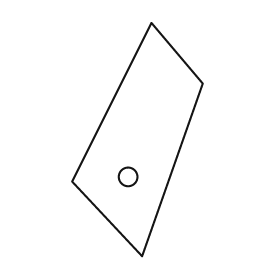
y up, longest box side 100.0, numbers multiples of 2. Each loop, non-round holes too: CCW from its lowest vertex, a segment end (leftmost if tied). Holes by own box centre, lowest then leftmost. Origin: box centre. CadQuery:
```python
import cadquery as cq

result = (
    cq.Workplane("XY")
    .moveTo(2.0, -50.0)
    .lineTo(28.0, 24.0)
    .lineTo(6.0, 50.0)
    .lineTo(-28.0, -18.0)
    .close()
    .moveTo(-4.0, -16.0)
    .circle(4.0)
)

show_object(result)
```